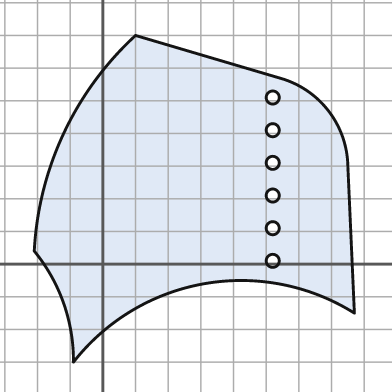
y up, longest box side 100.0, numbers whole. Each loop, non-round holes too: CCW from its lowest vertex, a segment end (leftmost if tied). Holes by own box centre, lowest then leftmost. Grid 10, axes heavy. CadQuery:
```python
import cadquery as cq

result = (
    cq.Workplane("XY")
    .moveTo(-9.0, -30.0)
    .threePointArc((31.0, -6.0), (77.0, -15.0))
    .lineTo(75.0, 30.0)
    .threePointArc((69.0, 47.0), (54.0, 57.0))
    .lineTo(10.0, 70.0)
    .threePointArc((-12.0, 40.0), (-21.0, 4.0))
    .threePointArc((-12.0, -12.0), (-9.0, -30.0))
    .close()
    .moveTo(52.0, 1.0)
    .circle(2.0)
    .moveTo(52.0, 11.0)
    .circle(2.0)
    .moveTo(52.0, 21.0)
    .circle(2.0)
    .moveTo(52.0, 31.0)
    .circle(2.0)
    .moveTo(52.0, 41.0)
    .circle(2.0)
    .moveTo(52.0, 51.0)
    .circle(2.0)
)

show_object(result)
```